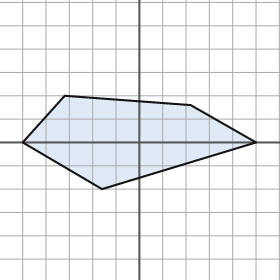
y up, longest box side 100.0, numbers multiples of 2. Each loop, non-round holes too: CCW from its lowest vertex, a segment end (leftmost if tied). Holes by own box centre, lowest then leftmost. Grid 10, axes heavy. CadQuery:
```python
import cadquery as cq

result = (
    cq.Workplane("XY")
    .moveTo(-16.0, -20.0)
    .lineTo(50.0, 0.0)
    .lineTo(22.0, 16.0)
    .lineTo(-32.0, 20.0)
    .lineTo(-50.0, 0.0)
    .close()
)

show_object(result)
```